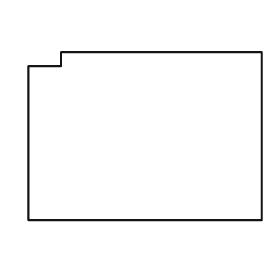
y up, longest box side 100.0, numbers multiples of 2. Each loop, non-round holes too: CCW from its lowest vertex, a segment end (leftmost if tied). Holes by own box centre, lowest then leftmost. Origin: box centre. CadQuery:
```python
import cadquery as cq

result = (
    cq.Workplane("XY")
    .moveTo(-50.0, -36.0)
    .lineTo(50.0, -36.0)
    .lineTo(50.0, 36.0)
    .lineTo(-36.0, 36.0)
    .lineTo(-36.0, 30.0)
    .lineTo(-50.0, 30.0)
    .close()
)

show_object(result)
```